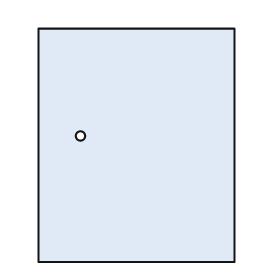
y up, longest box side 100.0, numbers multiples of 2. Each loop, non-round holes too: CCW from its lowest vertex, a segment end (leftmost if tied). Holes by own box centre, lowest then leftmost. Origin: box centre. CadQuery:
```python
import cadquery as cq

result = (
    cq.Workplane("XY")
    .moveTo(-42.0, -50.0)
    .lineTo(42.0, -50.0)
    .lineTo(42.0, 50.0)
    .lineTo(-42.0, 50.0)
    .close()
    .moveTo(-24.0, 4.0)
    .circle(2.0)
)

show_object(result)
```